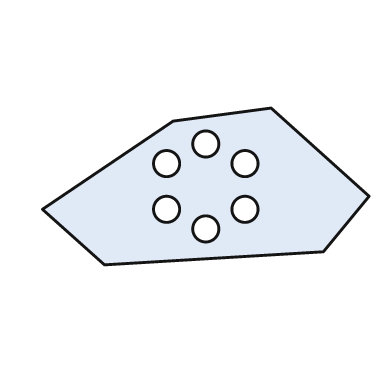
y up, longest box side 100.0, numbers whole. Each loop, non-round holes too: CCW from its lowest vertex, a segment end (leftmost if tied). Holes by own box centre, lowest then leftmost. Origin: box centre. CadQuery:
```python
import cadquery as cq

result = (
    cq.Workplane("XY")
    .moveTo(-31.0, -24.0)
    .lineTo(36.0, -20.0)
    .lineTo(50.0, -3.0)
    .lineTo(20.0, 24.0)
    .lineTo(-10.0, 20.0)
    .lineTo(-50.0, -7.0)
    .close()
    .moveTo(0.0, -13.0)
    .circle(4.0)
    .moveTo(-12.0, -7.0)
    .circle(4.0)
    .moveTo(12.0, -7.0)
    .circle(4.0)
    .moveTo(-12.0, 7.0)
    .circle(4.0)
    .moveTo(12.0, 7.0)
    .circle(4.0)
    .moveTo(0.0, 13.0)
    .circle(4.0)
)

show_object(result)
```